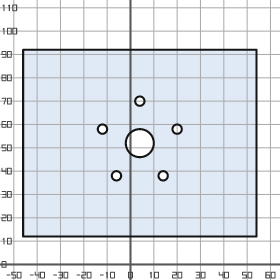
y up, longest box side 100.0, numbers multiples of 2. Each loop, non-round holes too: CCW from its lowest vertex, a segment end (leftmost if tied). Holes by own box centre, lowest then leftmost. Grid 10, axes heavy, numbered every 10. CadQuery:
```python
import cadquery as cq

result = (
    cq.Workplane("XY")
    .moveTo(-46.0, 12.0)
    .lineTo(54.0, 12.0)
    .lineTo(54.0, 92.0)
    .lineTo(-46.0, 92.0)
    .close()
    .moveTo(-6.0, 38.0)
    .circle(2.0)
    .moveTo(14.0, 38.0)
    .circle(2.0)
    .moveTo(4.0, 52.0)
    .circle(6.0)
    .moveTo(-12.0, 58.0)
    .circle(2.0)
    .moveTo(20.0, 58.0)
    .circle(2.0)
    .moveTo(4.0, 70.0)
    .circle(2.0)
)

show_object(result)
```